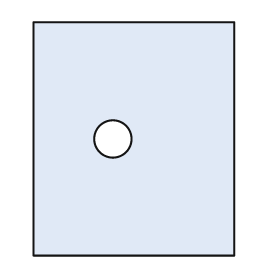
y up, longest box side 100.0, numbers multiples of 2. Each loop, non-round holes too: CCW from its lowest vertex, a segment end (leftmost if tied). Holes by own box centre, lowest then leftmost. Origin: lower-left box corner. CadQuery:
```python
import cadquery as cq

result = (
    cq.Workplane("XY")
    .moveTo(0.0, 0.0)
    .lineTo(86.0, 0.0)
    .lineTo(86.0, 100.0)
    .lineTo(0.0, 100.0)
    .close()
    .moveTo(34.0, 50.0)
    .circle(8.0)
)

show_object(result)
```